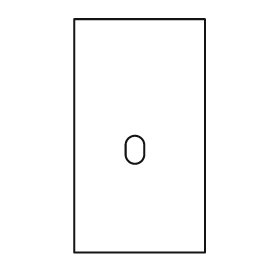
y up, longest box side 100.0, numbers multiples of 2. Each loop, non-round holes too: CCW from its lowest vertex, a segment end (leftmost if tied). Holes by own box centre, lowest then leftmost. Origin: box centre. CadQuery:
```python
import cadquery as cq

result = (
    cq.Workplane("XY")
    .moveTo(-28.0, -50.0)
    .lineTo(28.0, -50.0)
    .lineTo(28.0, 50.0)
    .lineTo(-28.0, 50.0)
    .close()
    .moveTo(-6.0, -8.0)
    .threePointArc((-2.0, -12.0), (2.0, -8.0))
    .lineTo(2.0, -4.0)
    .threePointArc((-2.0, 0.0), (-6.0, -4.0))
    .close()
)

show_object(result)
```